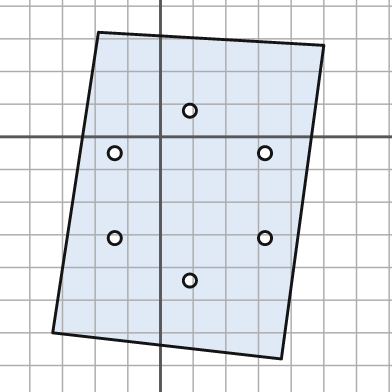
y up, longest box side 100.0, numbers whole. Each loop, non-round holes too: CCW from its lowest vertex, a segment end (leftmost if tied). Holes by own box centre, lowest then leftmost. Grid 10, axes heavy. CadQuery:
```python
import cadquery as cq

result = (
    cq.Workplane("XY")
    .moveTo(37.0, -68.0)
    .lineTo(50.0, 28.0)
    .lineTo(-19.0, 32.0)
    .lineTo(-33.0, -60.0)
    .close()
    .moveTo(9.0, -44.0)
    .circle(2.0)
    .moveTo(-14.0, -31.0)
    .circle(2.0)
    .moveTo(32.0, -31.0)
    .circle(2.0)
    .moveTo(-14.0, -5.0)
    .circle(2.0)
    .moveTo(32.0, -5.0)
    .circle(2.0)
    .moveTo(9.0, 8.0)
    .circle(2.0)
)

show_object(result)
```